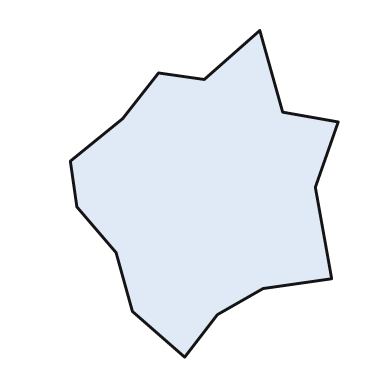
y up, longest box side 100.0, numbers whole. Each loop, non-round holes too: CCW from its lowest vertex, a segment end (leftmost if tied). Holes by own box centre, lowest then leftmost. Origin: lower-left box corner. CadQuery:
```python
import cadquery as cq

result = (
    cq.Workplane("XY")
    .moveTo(35.0, 0.0)
    .lineTo(45.0, 13.0)
    .lineTo(59.0, 21.0)
    .lineTo(80.0, 24.0)
    .lineTo(75.0, 52.0)
    .lineTo(82.0, 72.0)
    .lineTo(65.0, 75.0)
    .lineTo(58.0, 100.0)
    .lineTo(41.0, 85.0)
    .lineTo(27.0, 87.0)
    .lineTo(16.0, 73.0)
    .lineTo(0.0, 60.0)
    .lineTo(2.0, 46.0)
    .lineTo(14.0, 32.0)
    .lineTo(19.0, 14.0)
    .close()
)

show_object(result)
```